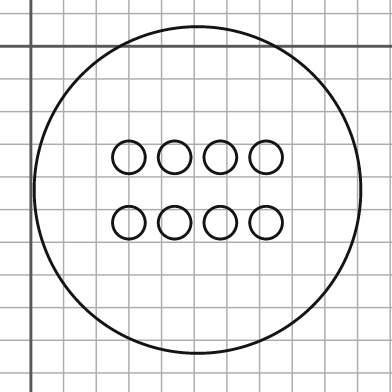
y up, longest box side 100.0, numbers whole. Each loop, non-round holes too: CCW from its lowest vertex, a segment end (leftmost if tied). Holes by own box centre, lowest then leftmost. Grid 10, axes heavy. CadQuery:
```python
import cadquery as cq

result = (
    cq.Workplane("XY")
    .moveTo(51.0, -44.0)
    .circle(50.0)
    .moveTo(30.0, -54.0)
    .circle(5.0)
    .moveTo(44.0, -54.0)
    .circle(5.0)
    .moveTo(58.0, -54.0)
    .circle(5.0)
    .moveTo(72.0, -54.0)
    .circle(5.0)
    .moveTo(30.0, -34.0)
    .circle(5.0)
    .moveTo(44.0, -34.0)
    .circle(5.0)
    .moveTo(58.0, -34.0)
    .circle(5.0)
    .moveTo(72.0, -34.0)
    .circle(5.0)
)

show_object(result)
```